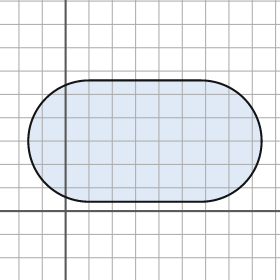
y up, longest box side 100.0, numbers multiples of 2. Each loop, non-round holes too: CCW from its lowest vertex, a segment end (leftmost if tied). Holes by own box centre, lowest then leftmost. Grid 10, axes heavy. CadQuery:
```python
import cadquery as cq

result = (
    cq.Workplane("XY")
    .moveTo(10.0, 4.0)
    .lineTo(58.0, 4.0)
    .threePointArc((84.0, 30.0), (58.0, 56.0))
    .lineTo(10.0, 56.0)
    .threePointArc((-16.0, 30.0), (10.0, 4.0))
    .close()
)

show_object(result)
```